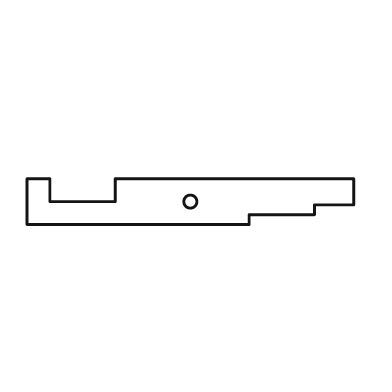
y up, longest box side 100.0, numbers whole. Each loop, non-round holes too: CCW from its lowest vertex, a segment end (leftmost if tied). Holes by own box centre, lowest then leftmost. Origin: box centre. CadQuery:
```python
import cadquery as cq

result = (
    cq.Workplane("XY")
    .moveTo(-50.0, -7.0)
    .lineTo(18.0, -7.0)
    .lineTo(18.0, -4.0)
    .lineTo(38.0, -4.0)
    .lineTo(38.0, -1.0)
    .lineTo(50.0, -1.0)
    .lineTo(50.0, 7.0)
    .lineTo(-23.0, 7.0)
    .lineTo(-23.0, 0.0)
    .lineTo(-43.0, 0.0)
    .lineTo(-43.0, 7.0)
    .lineTo(-50.0, 7.0)
    .close()
    .moveTo(0.0, 0.0)
    .circle(2.0)
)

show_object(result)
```